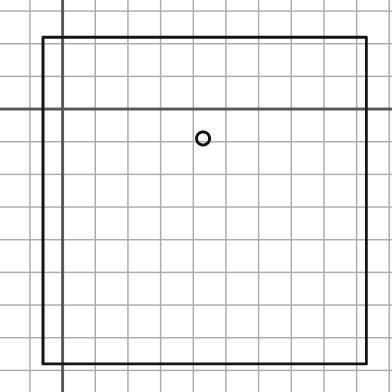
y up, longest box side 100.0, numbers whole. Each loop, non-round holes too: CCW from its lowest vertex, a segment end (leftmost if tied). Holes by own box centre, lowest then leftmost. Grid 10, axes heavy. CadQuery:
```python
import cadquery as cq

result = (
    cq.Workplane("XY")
    .moveTo(-6.0, -78.0)
    .lineTo(93.0, -78.0)
    .lineTo(93.0, 22.0)
    .lineTo(-6.0, 22.0)
    .close()
    .moveTo(43.0, -9.0)
    .circle(2.0)
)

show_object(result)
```